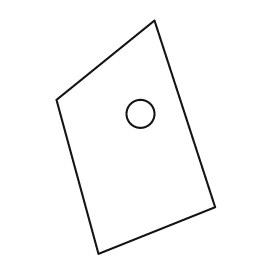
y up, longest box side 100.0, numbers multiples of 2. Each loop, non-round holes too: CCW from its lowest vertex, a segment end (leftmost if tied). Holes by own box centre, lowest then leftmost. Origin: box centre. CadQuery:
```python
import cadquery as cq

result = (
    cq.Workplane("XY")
    .moveTo(-16.0, -50.0)
    .lineTo(34.0, -30.0)
    .lineTo(8.0, 50.0)
    .lineTo(-34.0, 16.0)
    .close()
    .moveTo(2.0, 10.0)
    .circle(6.0)
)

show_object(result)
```